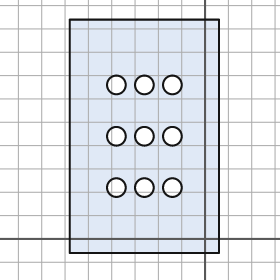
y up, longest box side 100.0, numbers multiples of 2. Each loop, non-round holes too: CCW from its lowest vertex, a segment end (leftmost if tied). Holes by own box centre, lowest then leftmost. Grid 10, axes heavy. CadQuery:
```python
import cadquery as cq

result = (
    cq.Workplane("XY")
    .moveTo(-58.0, -6.0)
    .lineTo(6.0, -6.0)
    .lineTo(6.0, 94.0)
    .lineTo(-58.0, 94.0)
    .close()
    .moveTo(-38.0, 22.0)
    .circle(4.0)
    .moveTo(-26.0, 22.0)
    .circle(4.0)
    .moveTo(-14.0, 22.0)
    .circle(4.0)
    .moveTo(-38.0, 44.0)
    .circle(4.0)
    .moveTo(-26.0, 44.0)
    .circle(4.0)
    .moveTo(-14.0, 44.0)
    .circle(4.0)
    .moveTo(-38.0, 66.0)
    .circle(4.0)
    .moveTo(-26.0, 66.0)
    .circle(4.0)
    .moveTo(-14.0, 66.0)
    .circle(4.0)
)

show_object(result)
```